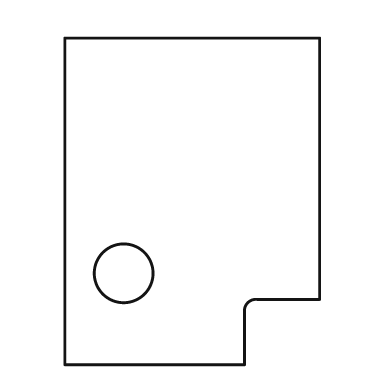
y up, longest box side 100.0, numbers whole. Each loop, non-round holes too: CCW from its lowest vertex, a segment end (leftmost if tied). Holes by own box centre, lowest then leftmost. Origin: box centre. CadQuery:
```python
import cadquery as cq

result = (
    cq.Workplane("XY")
    .moveTo(-39.0, -50.0)
    .lineTo(16.0, -50.0)
    .lineTo(16.0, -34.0)
    .threePointArc((17.0, -31.0), (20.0, -30.0))
    .lineTo(39.0, -30.0)
    .lineTo(39.0, 50.0)
    .lineTo(-39.0, 50.0)
    .close()
    .moveTo(-21.0, -22.0)
    .circle(9.0)
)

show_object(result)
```